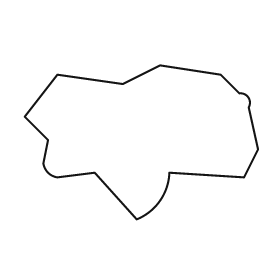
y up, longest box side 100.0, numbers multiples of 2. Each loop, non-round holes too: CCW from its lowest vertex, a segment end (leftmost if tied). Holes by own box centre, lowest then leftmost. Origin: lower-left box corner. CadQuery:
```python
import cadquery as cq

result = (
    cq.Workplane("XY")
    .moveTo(48.0, 0.0)
    .threePointArc((58.0, 8.0), (62.0, 20.0))
    .lineTo(94.0, 18.0)
    .lineTo(100.0, 30.0)
    .lineTo(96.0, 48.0)
    .threePointArc((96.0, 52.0), (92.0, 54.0))
    .lineTo(84.0, 62.0)
    .lineTo(58.0, 66.0)
    .lineTo(42.0, 58.0)
    .lineTo(14.0, 62.0)
    .lineTo(0.0, 44.0)
    .lineTo(10.0, 34.0)
    .lineTo(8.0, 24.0)
    .threePointArc((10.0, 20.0), (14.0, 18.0))
    .lineTo(30.0, 20.0)
    .close()
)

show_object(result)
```